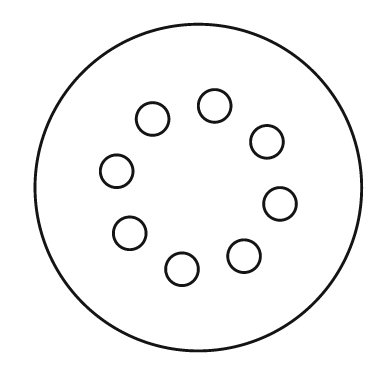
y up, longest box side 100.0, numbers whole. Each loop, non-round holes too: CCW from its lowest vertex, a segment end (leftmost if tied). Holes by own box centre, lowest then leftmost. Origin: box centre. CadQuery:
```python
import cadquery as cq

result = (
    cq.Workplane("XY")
    .moveTo(0.0, 0.0)
    .circle(50.0)
    .moveTo(-5.0, -25.0)
    .circle(5.0)
    .moveTo(14.0, -21.0)
    .circle(5.0)
    .moveTo(-21.0, -14.0)
    .circle(5.0)
    .moveTo(25.0, -5.0)
    .circle(5.0)
    .moveTo(-25.0, 5.0)
    .circle(5.0)
    .moveTo(21.0, 14.0)
    .circle(5.0)
    .moveTo(-14.0, 21.0)
    .circle(5.0)
    .moveTo(5.0, 25.0)
    .circle(5.0)
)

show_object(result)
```